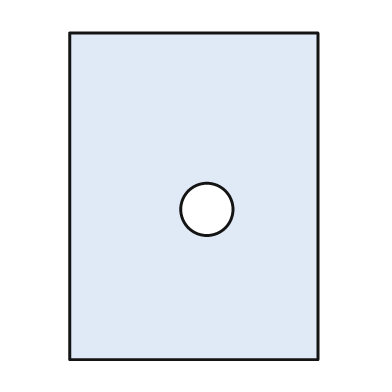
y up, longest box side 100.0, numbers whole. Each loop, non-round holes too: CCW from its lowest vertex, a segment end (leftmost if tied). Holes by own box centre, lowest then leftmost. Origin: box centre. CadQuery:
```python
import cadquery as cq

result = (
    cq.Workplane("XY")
    .moveTo(-38.0, -50.0)
    .lineTo(38.0, -50.0)
    .lineTo(38.0, 50.0)
    .lineTo(-38.0, 50.0)
    .close()
    .moveTo(4.0, -4.0)
    .circle(8.0)
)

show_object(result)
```